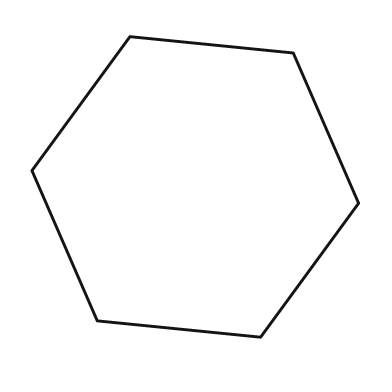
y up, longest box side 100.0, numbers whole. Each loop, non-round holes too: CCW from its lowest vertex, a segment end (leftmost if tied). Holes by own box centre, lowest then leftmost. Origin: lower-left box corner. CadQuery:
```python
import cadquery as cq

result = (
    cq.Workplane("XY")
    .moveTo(70.0, 0.0)
    .lineTo(100.0, 41.0)
    .lineTo(80.0, 87.0)
    .lineTo(30.0, 92.0)
    .lineTo(0.0, 51.0)
    .lineTo(20.0, 5.0)
    .close()
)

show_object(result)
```